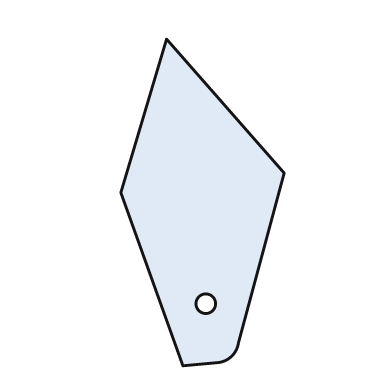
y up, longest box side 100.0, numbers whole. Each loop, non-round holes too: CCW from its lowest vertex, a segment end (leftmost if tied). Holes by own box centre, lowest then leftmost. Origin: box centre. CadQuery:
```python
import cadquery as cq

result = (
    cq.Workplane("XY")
    .moveTo(-6.0, -50.0)
    .lineTo(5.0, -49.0)
    .threePointArc((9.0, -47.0), (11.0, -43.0))
    .lineTo(25.0, 9.0)
    .lineTo(-11.0, 50.0)
    .lineTo(-25.0, 3.0)
    .close()
    .moveTo(1.0, -31.0)
    .circle(3.0)
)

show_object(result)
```